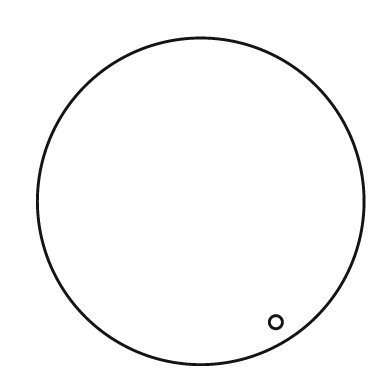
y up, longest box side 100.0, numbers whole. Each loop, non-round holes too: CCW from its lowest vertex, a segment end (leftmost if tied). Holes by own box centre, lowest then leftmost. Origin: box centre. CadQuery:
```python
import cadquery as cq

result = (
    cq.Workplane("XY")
    .moveTo(0.0, 0.0)
    .circle(50.0)
    .moveTo(23.0, -37.0)
    .circle(2.0)
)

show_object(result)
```